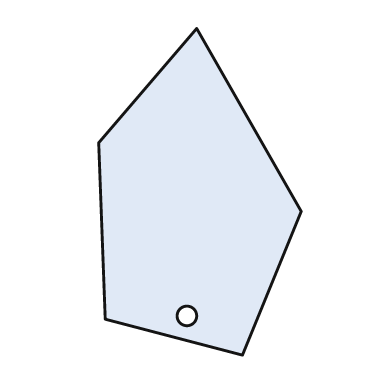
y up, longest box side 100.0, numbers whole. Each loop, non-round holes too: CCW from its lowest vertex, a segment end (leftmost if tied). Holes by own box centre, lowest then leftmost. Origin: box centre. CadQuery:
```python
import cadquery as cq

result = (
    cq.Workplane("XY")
    .moveTo(13.0, -50.0)
    .lineTo(31.0, -6.0)
    .lineTo(-1.0, 50.0)
    .lineTo(-31.0, 15.0)
    .lineTo(-29.0, -39.0)
    .close()
    .moveTo(-4.0, -38.0)
    .circle(3.0)
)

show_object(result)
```